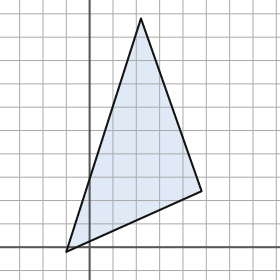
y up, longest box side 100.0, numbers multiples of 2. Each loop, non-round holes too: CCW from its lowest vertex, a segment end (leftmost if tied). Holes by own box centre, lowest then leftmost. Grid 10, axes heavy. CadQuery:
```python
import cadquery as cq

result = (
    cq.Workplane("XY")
    .moveTo(-10.0, -2.0)
    .lineTo(48.0, 24.0)
    .lineTo(22.0, 98.0)
    .close()
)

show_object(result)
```